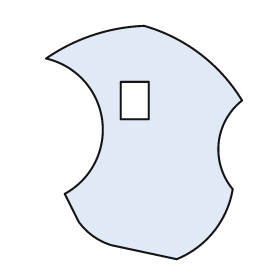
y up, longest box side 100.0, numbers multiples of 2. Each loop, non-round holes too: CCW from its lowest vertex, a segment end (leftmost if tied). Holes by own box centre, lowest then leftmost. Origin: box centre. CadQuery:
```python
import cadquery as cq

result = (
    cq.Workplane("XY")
    .moveTo(14.0, -50.0)
    .threePointArc((30.0, -38.0), (38.0, -20.0))
    .threePointArc((32.0, 0.0), (42.0, 18.0))
    .threePointArc((24.0, 38.0), (0.0, 50.0))
    .threePointArc((-22.0, 46.0), (-42.0, 36.0))
    .threePointArc((-18.0, 10.0), (-34.0, -22.0))
    .lineTo(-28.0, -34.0)
    .threePointArc((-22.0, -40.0), (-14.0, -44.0))
    .close()
    .moveTo(-10.0, 10.0)
    .lineTo(2.0, 10.0)
    .lineTo(2.0, 26.0)
    .lineTo(-10.0, 26.0)
    .close()
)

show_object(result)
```